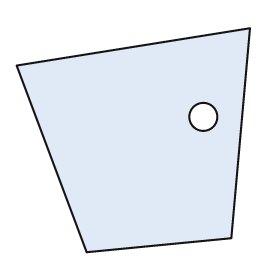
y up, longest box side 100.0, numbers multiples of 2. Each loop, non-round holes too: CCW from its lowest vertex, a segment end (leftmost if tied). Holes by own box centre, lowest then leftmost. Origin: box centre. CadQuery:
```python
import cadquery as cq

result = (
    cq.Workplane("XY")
    .moveTo(-20.0, -48.0)
    .lineTo(42.0, -42.0)
    .lineTo(50.0, 48.0)
    .lineTo(-50.0, 32.0)
    .close()
    .moveTo(30.0, 10.0)
    .circle(6.0)
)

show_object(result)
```